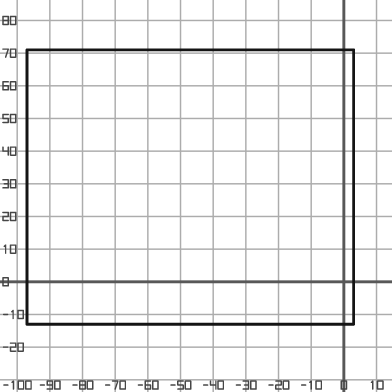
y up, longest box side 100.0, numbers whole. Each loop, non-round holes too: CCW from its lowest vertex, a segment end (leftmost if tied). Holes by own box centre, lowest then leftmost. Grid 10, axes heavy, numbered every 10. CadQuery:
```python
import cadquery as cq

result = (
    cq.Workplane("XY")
    .moveTo(-97.0, -13.0)
    .lineTo(3.0, -13.0)
    .lineTo(3.0, 71.0)
    .lineTo(-97.0, 71.0)
    .close()
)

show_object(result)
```